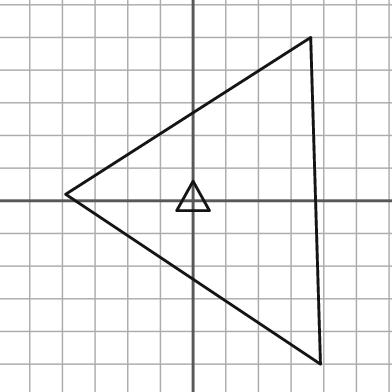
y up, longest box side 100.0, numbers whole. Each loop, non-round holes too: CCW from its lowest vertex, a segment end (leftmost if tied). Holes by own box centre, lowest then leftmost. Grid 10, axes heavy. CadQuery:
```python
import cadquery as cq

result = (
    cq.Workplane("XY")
    .moveTo(39.0, -50.0)
    .lineTo(36.0, 50.0)
    .lineTo(-39.0, 2.0)
    .close()
    .moveTo(-5.0, -3.0)
    .lineTo(5.0, -3.0)
    .lineTo(0.0, 6.0)
    .close()
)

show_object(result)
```